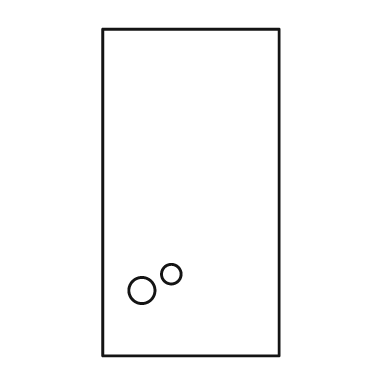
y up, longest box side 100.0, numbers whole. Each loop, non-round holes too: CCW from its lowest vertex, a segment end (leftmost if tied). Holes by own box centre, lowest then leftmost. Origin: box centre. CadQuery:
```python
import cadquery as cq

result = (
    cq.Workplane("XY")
    .moveTo(-27.0, -50.0)
    .lineTo(27.0, -50.0)
    .lineTo(27.0, 50.0)
    .lineTo(-27.0, 50.0)
    .close()
    .moveTo(-15.0, -30.0)
    .circle(4.0)
    .moveTo(-6.0, -25.0)
    .circle(3.0)
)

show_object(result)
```